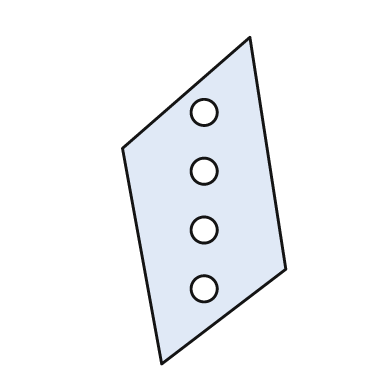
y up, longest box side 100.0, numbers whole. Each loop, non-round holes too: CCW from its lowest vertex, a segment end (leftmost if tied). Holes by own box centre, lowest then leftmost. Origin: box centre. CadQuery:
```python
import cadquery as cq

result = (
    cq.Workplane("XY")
    .moveTo(-13.0, -50.0)
    .lineTo(25.0, -21.0)
    .lineTo(14.0, 50.0)
    .lineTo(-25.0, 16.0)
    .close()
    .moveTo(0.0, -27.0)
    .circle(4.0)
    .moveTo(0.0, -9.0)
    .circle(4.0)
    .moveTo(0.0, 9.0)
    .circle(4.0)
    .moveTo(0.0, 27.0)
    .circle(4.0)
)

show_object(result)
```